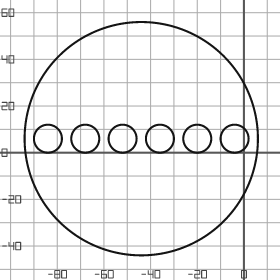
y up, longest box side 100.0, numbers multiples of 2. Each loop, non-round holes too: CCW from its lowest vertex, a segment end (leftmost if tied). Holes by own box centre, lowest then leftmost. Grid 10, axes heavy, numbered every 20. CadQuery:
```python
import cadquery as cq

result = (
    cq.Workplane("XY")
    .moveTo(-44.0, 6.0)
    .circle(50.0)
    .moveTo(-84.0, 6.0)
    .circle(6.0)
    .moveTo(-68.0, 6.0)
    .circle(6.0)
    .moveTo(-52.0, 6.0)
    .circle(6.0)
    .moveTo(-36.0, 6.0)
    .circle(6.0)
    .moveTo(-20.0, 6.0)
    .circle(6.0)
    .moveTo(-4.0, 6.0)
    .circle(6.0)
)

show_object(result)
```